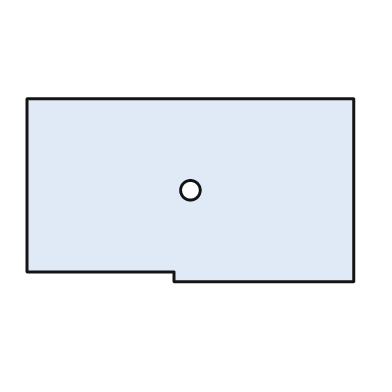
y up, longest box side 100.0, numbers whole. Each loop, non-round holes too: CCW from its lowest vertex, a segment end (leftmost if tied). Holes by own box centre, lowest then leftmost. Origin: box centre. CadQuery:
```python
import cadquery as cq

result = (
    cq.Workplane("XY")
    .moveTo(-5.0, -28.0)
    .lineTo(50.0, -28.0)
    .lineTo(50.0, 28.0)
    .lineTo(-50.0, 28.0)
    .lineTo(-50.0, -25.0)
    .lineTo(-5.0, -25.0)
    .close()
    .moveTo(0.0, 0.0)
    .circle(3.0)
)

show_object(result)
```